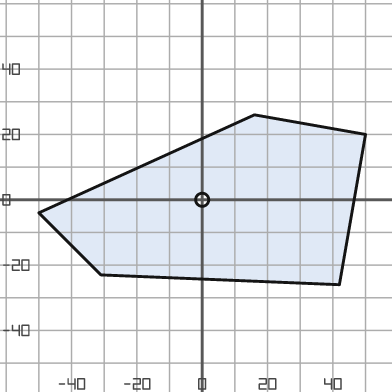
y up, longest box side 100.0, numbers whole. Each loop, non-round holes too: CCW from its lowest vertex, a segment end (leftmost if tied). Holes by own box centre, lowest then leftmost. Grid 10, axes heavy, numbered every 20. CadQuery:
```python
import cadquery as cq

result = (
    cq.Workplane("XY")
    .moveTo(42.0, -26.0)
    .lineTo(50.0, 20.0)
    .lineTo(16.0, 26.0)
    .lineTo(-50.0, -4.0)
    .lineTo(-31.0, -23.0)
    .close()
    .moveTo(0.0, 0.0)
    .circle(2.0)
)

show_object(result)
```